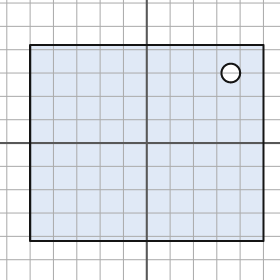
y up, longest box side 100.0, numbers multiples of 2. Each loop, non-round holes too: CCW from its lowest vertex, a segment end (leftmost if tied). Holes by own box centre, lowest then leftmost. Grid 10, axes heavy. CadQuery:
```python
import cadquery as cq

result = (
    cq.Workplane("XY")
    .moveTo(-50.0, -42.0)
    .lineTo(50.0, -42.0)
    .lineTo(50.0, 42.0)
    .lineTo(-50.0, 42.0)
    .close()
    .moveTo(36.0, 30.0)
    .circle(4.0)
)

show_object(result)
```